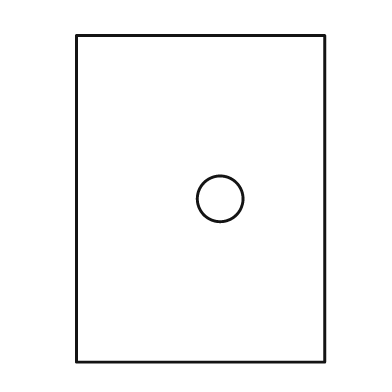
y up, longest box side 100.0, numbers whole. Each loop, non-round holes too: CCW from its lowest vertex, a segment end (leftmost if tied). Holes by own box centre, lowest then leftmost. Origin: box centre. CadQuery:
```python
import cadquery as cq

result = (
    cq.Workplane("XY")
    .moveTo(-38.0, -50.0)
    .lineTo(38.0, -50.0)
    .lineTo(38.0, 50.0)
    .lineTo(-38.0, 50.0)
    .close()
    .moveTo(6.0, 0.0)
    .circle(7.0)
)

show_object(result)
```